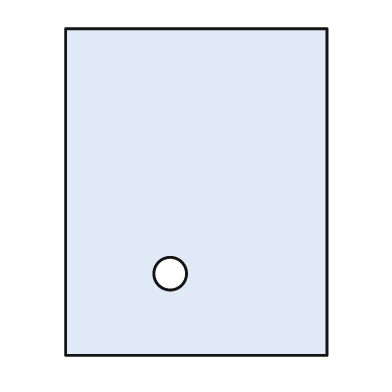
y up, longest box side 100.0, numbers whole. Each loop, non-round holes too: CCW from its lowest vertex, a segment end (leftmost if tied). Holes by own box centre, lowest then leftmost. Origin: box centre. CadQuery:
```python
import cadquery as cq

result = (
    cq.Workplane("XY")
    .moveTo(-40.0, -50.0)
    .lineTo(40.0, -50.0)
    .lineTo(40.0, 50.0)
    .lineTo(-40.0, 50.0)
    .close()
    .moveTo(-8.0, -25.0)
    .circle(5.0)
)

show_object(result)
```